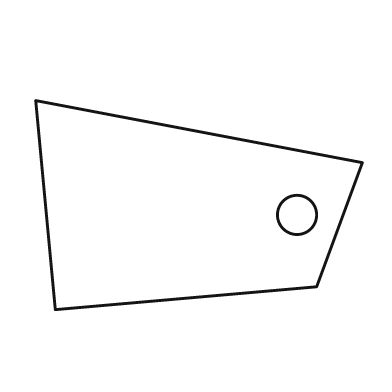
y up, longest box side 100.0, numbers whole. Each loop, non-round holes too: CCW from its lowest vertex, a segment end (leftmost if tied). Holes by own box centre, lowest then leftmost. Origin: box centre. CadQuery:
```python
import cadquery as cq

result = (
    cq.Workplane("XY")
    .moveTo(-44.0, -32.0)
    .lineTo(36.0, -25.0)
    .lineTo(50.0, 13.0)
    .lineTo(-50.0, 32.0)
    .close()
    .moveTo(30.0, -3.0)
    .circle(6.0)
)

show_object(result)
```